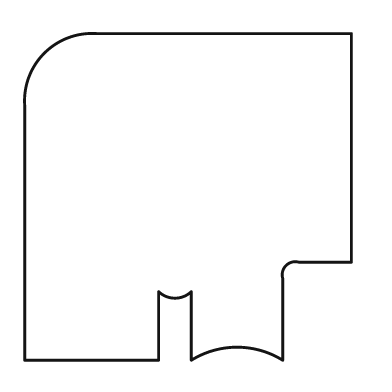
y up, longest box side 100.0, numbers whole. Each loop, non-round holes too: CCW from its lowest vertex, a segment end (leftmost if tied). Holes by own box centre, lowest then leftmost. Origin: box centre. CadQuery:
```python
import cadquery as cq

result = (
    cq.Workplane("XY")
    .moveTo(-50.0, -50.0)
    .lineTo(-9.0, -50.0)
    .lineTo(-9.0, -29.0)
    .threePointArc((-4.0, -31.0), (1.0, -29.0))
    .lineTo(1.0, -50.0)
    .threePointArc((15.0, -46.0), (29.0, -50.0))
    .lineTo(29.0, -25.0)
    .threePointArc((30.0, -21.0), (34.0, -20.0))
    .lineTo(50.0, -20.0)
    .lineTo(50.0, 50.0)
    .lineTo(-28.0, 50.0)
    .threePointArc((-44.0, 44.0), (-50.0, 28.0))
    .close()
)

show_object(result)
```